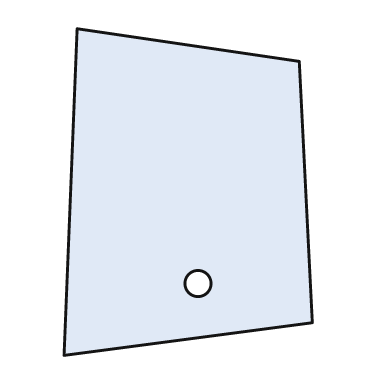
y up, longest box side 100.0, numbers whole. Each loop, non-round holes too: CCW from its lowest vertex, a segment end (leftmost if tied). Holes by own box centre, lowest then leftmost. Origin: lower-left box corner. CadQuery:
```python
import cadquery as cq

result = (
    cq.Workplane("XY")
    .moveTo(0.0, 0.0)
    .lineTo(76.0, 10.0)
    .lineTo(72.0, 90.0)
    .lineTo(4.0, 100.0)
    .close()
    .moveTo(41.0, 22.0)
    .circle(4.0)
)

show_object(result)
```